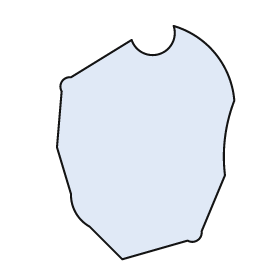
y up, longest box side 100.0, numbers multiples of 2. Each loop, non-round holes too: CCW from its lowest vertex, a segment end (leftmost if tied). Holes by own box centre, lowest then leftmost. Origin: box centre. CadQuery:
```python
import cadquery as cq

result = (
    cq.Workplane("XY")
    .moveTo(-10.0, -50.0)
    .lineTo(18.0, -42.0)
    .threePointArc((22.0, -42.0), (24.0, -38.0))
    .lineTo(34.0, -14.0)
    .threePointArc((34.0, 2.0), (38.0, 18.0))
    .threePointArc((30.0, 38.0), (12.0, 50.0))
    .threePointArc((6.0, 38.0), (-6.0, 44.0))
    .lineTo(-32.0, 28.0)
    .threePointArc((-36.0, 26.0), (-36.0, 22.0))
    .lineTo(-38.0, -2.0)
    .lineTo(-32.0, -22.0)
    .threePointArc((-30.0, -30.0), (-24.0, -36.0))
    .close()
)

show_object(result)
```